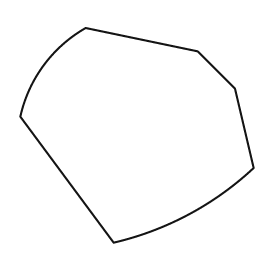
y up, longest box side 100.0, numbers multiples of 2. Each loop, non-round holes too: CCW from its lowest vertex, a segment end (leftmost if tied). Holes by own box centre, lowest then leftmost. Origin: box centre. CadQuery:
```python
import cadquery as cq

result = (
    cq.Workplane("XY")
    .moveTo(-10.0, -46.0)
    .threePointArc((22.0, -34.0), (50.0, -14.0))
    .lineTo(42.0, 20.0)
    .lineTo(26.0, 36.0)
    .lineTo(-22.0, 46.0)
    .threePointArc((-40.0, 30.0), (-50.0, 8.0))
    .close()
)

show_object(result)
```